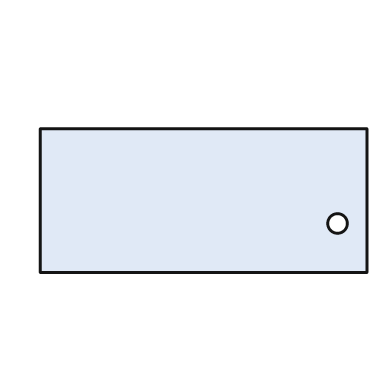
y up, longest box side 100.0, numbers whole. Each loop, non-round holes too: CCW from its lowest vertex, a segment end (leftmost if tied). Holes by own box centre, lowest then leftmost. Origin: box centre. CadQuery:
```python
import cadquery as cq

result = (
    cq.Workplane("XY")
    .moveTo(-50.0, -22.0)
    .lineTo(50.0, -22.0)
    .lineTo(50.0, 22.0)
    .lineTo(-50.0, 22.0)
    .close()
    .moveTo(41.0, -7.0)
    .circle(3.0)
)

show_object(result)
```